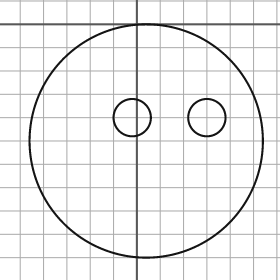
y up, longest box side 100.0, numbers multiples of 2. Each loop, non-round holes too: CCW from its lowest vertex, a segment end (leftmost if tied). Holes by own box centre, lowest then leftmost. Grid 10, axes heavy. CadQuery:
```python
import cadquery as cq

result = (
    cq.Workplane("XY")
    .moveTo(4.0, -50.0)
    .circle(50.0)
    .moveTo(-2.0, -40.0)
    .circle(8.0)
    .moveTo(30.0, -40.0)
    .circle(8.0)
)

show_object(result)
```